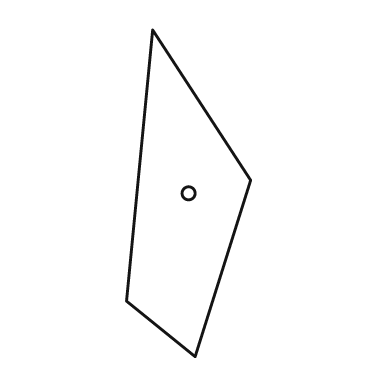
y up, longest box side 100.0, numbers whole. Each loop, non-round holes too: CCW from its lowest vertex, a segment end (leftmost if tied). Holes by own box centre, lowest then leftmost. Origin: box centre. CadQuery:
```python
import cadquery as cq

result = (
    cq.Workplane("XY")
    .moveTo(2.0, -50.0)
    .lineTo(19.0, 4.0)
    .lineTo(-11.0, 50.0)
    .lineTo(-19.0, -33.0)
    .close()
    .moveTo(0.0, 0.0)
    .circle(2.0)
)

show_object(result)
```